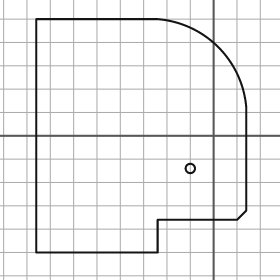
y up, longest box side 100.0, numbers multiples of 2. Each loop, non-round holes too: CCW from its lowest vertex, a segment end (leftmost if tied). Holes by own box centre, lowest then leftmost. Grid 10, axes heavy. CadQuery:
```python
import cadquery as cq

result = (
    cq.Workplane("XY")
    .moveTo(-76.0, -50.0)
    .lineTo(-24.0, -50.0)
    .lineTo(-24.0, -36.0)
    .lineTo(10.0, -36.0)
    .lineTo(14.0, -32.0)
    .lineTo(14.0, 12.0)
    .threePointArc((2.0, 38.0), (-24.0, 50.0))
    .lineTo(-76.0, 50.0)
    .close()
    .moveTo(-10.0, -14.0)
    .circle(2.0)
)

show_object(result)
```